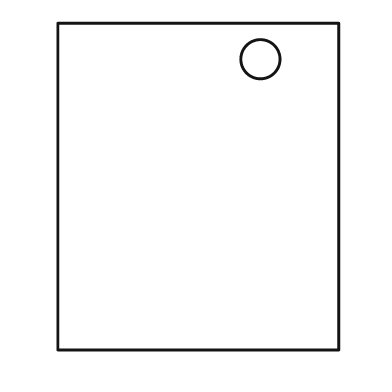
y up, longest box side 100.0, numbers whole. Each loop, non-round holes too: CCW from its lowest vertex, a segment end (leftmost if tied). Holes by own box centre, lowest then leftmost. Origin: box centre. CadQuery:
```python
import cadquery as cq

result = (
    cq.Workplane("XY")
    .moveTo(-43.0, -50.0)
    .lineTo(43.0, -50.0)
    .lineTo(43.0, 50.0)
    .lineTo(-43.0, 50.0)
    .close()
    .moveTo(19.0, 39.0)
    .circle(6.0)
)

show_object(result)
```